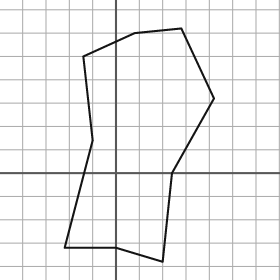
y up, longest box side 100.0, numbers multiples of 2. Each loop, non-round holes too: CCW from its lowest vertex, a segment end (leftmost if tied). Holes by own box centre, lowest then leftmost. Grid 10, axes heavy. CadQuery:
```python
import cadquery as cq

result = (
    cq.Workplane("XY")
    .moveTo(20.0, -38.0)
    .lineTo(24.0, 0.0)
    .lineTo(42.0, 32.0)
    .lineTo(28.0, 62.0)
    .lineTo(8.0, 60.0)
    .lineTo(-14.0, 50.0)
    .lineTo(-10.0, 14.0)
    .lineTo(-22.0, -32.0)
    .lineTo(0.0, -32.0)
    .close()
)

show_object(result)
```